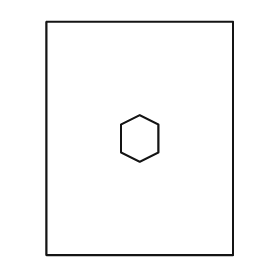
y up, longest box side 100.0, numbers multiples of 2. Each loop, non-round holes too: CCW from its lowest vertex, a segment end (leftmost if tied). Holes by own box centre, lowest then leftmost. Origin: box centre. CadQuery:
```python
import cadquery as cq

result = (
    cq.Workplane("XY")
    .moveTo(-40.0, -50.0)
    .lineTo(40.0, -50.0)
    .lineTo(40.0, 50.0)
    .lineTo(-40.0, 50.0)
    .close()
    .moveTo(0.0, -10.0)
    .lineTo(8.0, -6.0)
    .lineTo(8.0, 6.0)
    .lineTo(0.0, 10.0)
    .lineTo(-8.0, 6.0)
    .lineTo(-8.0, -6.0)
    .close()
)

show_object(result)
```